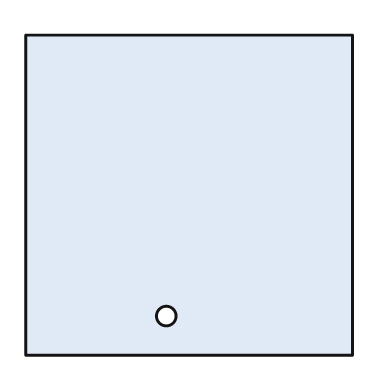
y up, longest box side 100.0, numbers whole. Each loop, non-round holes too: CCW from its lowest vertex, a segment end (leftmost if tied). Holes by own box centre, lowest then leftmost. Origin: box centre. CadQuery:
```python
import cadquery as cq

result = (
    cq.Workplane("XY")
    .moveTo(-50.0, -49.0)
    .lineTo(50.0, -49.0)
    .lineTo(50.0, 49.0)
    .lineTo(-50.0, 49.0)
    .close()
    .moveTo(-7.0, -37.0)
    .circle(3.0)
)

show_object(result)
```